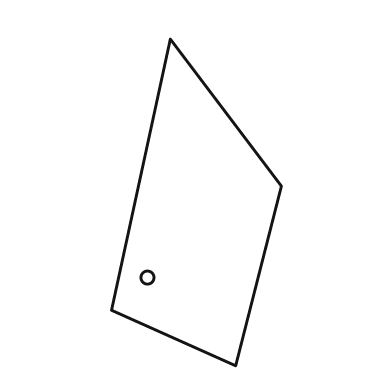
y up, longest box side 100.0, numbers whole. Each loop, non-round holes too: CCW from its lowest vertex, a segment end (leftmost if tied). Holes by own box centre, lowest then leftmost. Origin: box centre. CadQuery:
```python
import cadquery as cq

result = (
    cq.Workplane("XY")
    .moveTo(12.0, -50.0)
    .lineTo(26.0, 5.0)
    .lineTo(-8.0, 50.0)
    .lineTo(-26.0, -33.0)
    .close()
    .moveTo(-15.0, -23.0)
    .circle(2.0)
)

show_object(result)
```